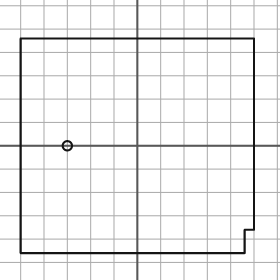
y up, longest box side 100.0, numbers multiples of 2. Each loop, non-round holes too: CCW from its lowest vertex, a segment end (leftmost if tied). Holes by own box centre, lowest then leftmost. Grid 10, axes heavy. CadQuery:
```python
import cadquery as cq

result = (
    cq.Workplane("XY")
    .moveTo(-50.0, -46.0)
    .lineTo(46.0, -46.0)
    .lineTo(46.0, -36.0)
    .lineTo(50.0, -36.0)
    .lineTo(50.0, 46.0)
    .lineTo(-50.0, 46.0)
    .close()
    .moveTo(-30.0, 0.0)
    .circle(2.0)
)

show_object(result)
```